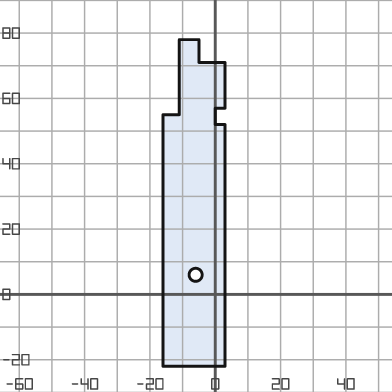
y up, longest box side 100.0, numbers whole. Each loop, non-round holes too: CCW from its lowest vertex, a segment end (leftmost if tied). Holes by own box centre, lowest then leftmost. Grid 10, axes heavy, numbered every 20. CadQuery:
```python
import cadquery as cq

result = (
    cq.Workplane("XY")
    .moveTo(-16.0, -22.0)
    .lineTo(3.0, -22.0)
    .lineTo(3.0, 52.0)
    .lineTo(0.0, 52.0)
    .lineTo(0.0, 57.0)
    .lineTo(3.0, 57.0)
    .lineTo(3.0, 71.0)
    .lineTo(-5.0, 71.0)
    .lineTo(-5.0, 78.0)
    .lineTo(-11.0, 78.0)
    .lineTo(-11.0, 55.0)
    .lineTo(-16.0, 55.0)
    .close()
    .moveTo(-6.0, 6.0)
    .circle(2.0)
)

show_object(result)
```